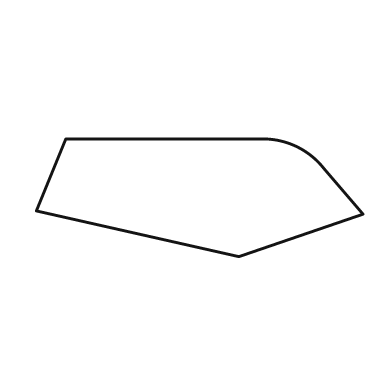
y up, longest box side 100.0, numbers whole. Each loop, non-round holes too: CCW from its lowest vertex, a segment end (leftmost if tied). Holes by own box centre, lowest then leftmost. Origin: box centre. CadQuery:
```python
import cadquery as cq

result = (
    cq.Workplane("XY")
    .moveTo(12.0, -18.0)
    .lineTo(50.0, -5.0)
    .lineTo(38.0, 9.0)
    .threePointArc((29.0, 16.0), (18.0, 18.0))
    .lineTo(-41.0, 18.0)
    .lineTo(-50.0, -4.0)
    .close()
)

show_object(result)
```